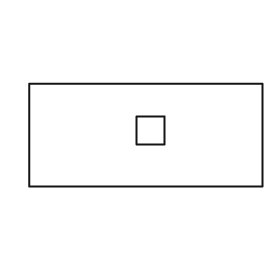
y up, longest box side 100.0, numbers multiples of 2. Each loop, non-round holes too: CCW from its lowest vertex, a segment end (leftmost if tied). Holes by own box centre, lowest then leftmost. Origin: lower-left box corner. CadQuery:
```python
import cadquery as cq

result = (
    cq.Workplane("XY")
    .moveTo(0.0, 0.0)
    .lineTo(100.0, 0.0)
    .lineTo(100.0, 44.0)
    .lineTo(0.0, 44.0)
    .close()
    .moveTo(46.0, 18.0)
    .lineTo(58.0, 18.0)
    .lineTo(58.0, 30.0)
    .lineTo(46.0, 30.0)
    .close()
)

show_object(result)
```